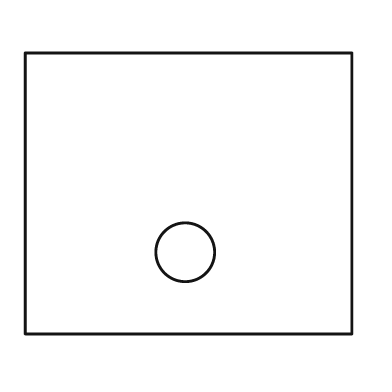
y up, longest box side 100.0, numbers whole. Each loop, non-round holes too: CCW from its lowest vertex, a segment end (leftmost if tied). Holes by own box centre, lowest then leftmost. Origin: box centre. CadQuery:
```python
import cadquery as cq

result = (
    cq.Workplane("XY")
    .moveTo(-50.0, -43.0)
    .lineTo(50.0, -43.0)
    .lineTo(50.0, 43.0)
    .lineTo(-50.0, 43.0)
    .close()
    .moveTo(-1.0, -18.0)
    .circle(9.0)
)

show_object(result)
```